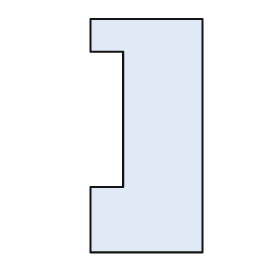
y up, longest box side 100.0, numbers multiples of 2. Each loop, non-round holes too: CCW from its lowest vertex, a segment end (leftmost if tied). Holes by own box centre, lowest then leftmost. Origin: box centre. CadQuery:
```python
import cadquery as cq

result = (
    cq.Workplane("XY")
    .moveTo(-24.0, -50.0)
    .lineTo(24.0, -50.0)
    .lineTo(24.0, 50.0)
    .lineTo(-24.0, 50.0)
    .lineTo(-24.0, 36.0)
    .lineTo(-10.0, 36.0)
    .lineTo(-10.0, -22.0)
    .lineTo(-24.0, -22.0)
    .close()
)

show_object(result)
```